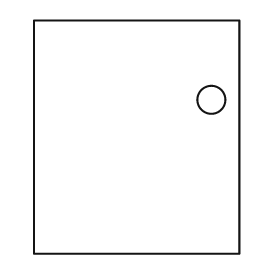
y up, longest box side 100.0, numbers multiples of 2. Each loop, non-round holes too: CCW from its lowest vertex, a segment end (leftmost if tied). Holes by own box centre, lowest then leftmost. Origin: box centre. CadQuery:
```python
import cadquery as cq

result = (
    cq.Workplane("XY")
    .moveTo(-44.0, -50.0)
    .lineTo(44.0, -50.0)
    .lineTo(44.0, 50.0)
    .lineTo(-44.0, 50.0)
    .close()
    .moveTo(32.0, 16.0)
    .circle(6.0)
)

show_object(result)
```